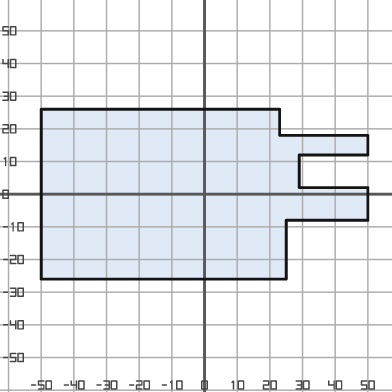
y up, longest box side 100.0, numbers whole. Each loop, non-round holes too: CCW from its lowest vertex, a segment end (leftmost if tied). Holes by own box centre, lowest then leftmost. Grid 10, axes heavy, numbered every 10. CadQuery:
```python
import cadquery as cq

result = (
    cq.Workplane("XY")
    .moveTo(-50.0, -26.0)
    .lineTo(25.0, -26.0)
    .lineTo(25.0, -8.0)
    .lineTo(50.0, -8.0)
    .lineTo(50.0, 2.0)
    .lineTo(29.0, 2.0)
    .lineTo(29.0, 12.0)
    .lineTo(50.0, 12.0)
    .lineTo(50.0, 18.0)
    .lineTo(23.0, 18.0)
    .lineTo(23.0, 26.0)
    .lineTo(-50.0, 26.0)
    .close()
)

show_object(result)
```